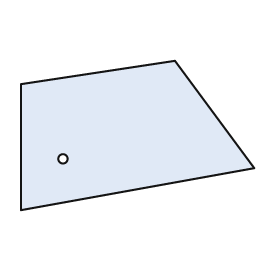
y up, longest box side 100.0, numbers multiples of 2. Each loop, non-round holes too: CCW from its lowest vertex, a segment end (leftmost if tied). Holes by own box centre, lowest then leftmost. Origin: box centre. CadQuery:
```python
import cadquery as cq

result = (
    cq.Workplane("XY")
    .moveTo(-50.0, -32.0)
    .lineTo(50.0, -14.0)
    .lineTo(16.0, 32.0)
    .lineTo(-50.0, 22.0)
    .close()
    .moveTo(-32.0, -10.0)
    .circle(2.0)
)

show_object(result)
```